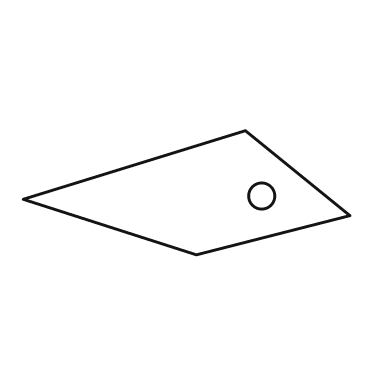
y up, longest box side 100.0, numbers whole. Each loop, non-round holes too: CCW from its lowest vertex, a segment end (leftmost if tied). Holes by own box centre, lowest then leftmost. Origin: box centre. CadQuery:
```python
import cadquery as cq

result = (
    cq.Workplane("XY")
    .moveTo(3.0, -19.0)
    .lineTo(50.0, -7.0)
    .lineTo(18.0, 19.0)
    .lineTo(-50.0, -2.0)
    .close()
    .moveTo(23.0, -1.0)
    .circle(4.0)
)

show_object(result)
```